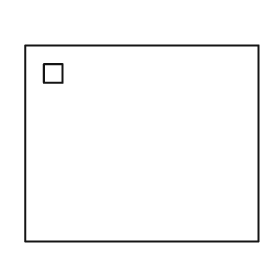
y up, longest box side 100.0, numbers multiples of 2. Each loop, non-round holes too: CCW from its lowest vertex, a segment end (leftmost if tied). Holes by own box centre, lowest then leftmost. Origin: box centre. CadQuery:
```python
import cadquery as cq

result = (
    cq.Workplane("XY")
    .moveTo(-50.0, -42.0)
    .lineTo(50.0, -42.0)
    .lineTo(50.0, 42.0)
    .lineTo(-50.0, 42.0)
    .close()
    .moveTo(-42.0, 26.0)
    .lineTo(-34.0, 26.0)
    .lineTo(-34.0, 34.0)
    .lineTo(-42.0, 34.0)
    .close()
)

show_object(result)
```